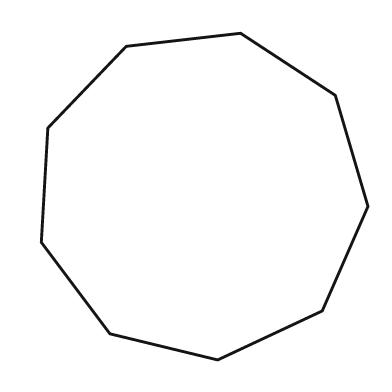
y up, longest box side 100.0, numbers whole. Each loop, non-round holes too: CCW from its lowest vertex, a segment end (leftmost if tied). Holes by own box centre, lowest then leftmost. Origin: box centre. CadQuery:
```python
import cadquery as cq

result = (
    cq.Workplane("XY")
    .moveTo(4.0, -50.0)
    .lineTo(36.0, -35.0)
    .lineTo(50.0, -3.0)
    .lineTo(40.0, 31.0)
    .lineTo(11.0, 50.0)
    .lineTo(-24.0, 46.0)
    .lineTo(-48.0, 21.0)
    .lineTo(-50.0, -14.0)
    .lineTo(-29.0, -42.0)
    .close()
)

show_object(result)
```